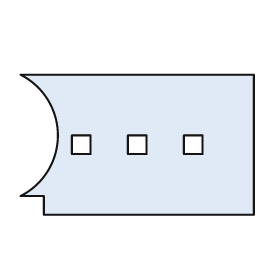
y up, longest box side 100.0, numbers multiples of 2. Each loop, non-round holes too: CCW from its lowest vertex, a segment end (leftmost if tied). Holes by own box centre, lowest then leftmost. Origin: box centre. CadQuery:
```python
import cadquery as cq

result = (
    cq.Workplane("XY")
    .moveTo(-40.0, -30.0)
    .lineTo(50.0, -30.0)
    .lineTo(50.0, 30.0)
    .lineTo(-50.0, 30.0)
    .threePointArc((-34.0, 4.0), (-50.0, -22.0))
    .lineTo(-40.0, -22.0)
    .close()
    .moveTo(-28.0, -4.0)
    .lineTo(-20.0, -4.0)
    .lineTo(-20.0, 4.0)
    .lineTo(-28.0, 4.0)
    .close()
    .moveTo(-4.0, -4.0)
    .lineTo(4.0, -4.0)
    .lineTo(4.0, 4.0)
    .lineTo(-4.0, 4.0)
    .close()
    .moveTo(20.0, -4.0)
    .lineTo(28.0, -4.0)
    .lineTo(28.0, 4.0)
    .lineTo(20.0, 4.0)
    .close()
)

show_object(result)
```